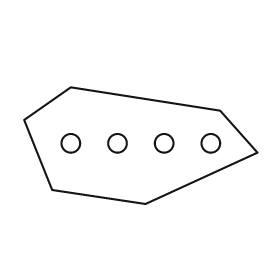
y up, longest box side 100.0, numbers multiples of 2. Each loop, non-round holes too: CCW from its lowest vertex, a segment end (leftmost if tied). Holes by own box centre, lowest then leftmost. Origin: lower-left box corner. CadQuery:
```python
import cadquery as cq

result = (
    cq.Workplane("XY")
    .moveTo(52.0, 0.0)
    .lineTo(100.0, 22.0)
    .lineTo(84.0, 40.0)
    .lineTo(20.0, 50.0)
    .lineTo(0.0, 36.0)
    .lineTo(12.0, 6.0)
    .close()
    .moveTo(20.0, 26.0)
    .circle(4.0)
    .moveTo(40.0, 26.0)
    .circle(4.0)
    .moveTo(60.0, 26.0)
    .circle(4.0)
    .moveTo(80.0, 26.0)
    .circle(4.0)
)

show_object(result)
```